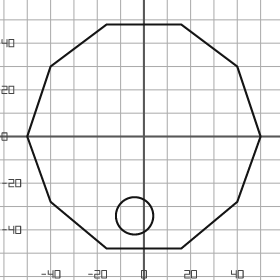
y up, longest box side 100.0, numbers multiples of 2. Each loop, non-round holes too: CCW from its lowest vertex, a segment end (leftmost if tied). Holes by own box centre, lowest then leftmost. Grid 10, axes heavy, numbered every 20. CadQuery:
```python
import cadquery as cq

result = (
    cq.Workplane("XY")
    .moveTo(-16.0, -48.0)
    .lineTo(16.0, -48.0)
    .lineTo(40.0, -28.0)
    .lineTo(50.0, 0.0)
    .lineTo(40.0, 30.0)
    .lineTo(16.0, 48.0)
    .lineTo(-16.0, 48.0)
    .lineTo(-40.0, 30.0)
    .lineTo(-50.0, 0.0)
    .lineTo(-40.0, -28.0)
    .close()
    .moveTo(-4.0, -34.0)
    .circle(8.0)
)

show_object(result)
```